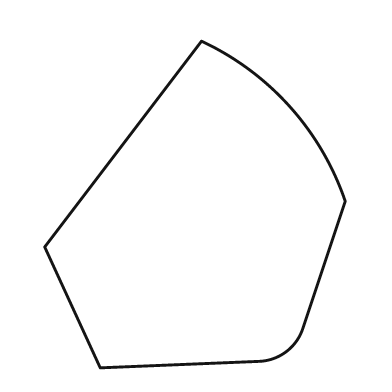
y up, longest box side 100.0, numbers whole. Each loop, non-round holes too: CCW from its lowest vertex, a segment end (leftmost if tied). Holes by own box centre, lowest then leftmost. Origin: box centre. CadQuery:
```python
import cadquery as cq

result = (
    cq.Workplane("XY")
    .moveTo(-29.0, -50.0)
    .lineTo(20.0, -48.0)
    .threePointArc((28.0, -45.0), (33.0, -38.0))
    .lineTo(46.0, 1.0)
    .threePointArc((29.0, 30.0), (2.0, 50.0))
    .lineTo(-46.0, -13.0)
    .close()
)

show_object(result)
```